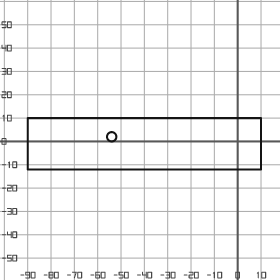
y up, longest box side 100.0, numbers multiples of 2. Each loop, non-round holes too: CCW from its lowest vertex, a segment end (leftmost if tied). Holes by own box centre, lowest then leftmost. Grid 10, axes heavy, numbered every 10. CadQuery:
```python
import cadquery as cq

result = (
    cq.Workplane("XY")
    .moveTo(-90.0, -12.0)
    .lineTo(10.0, -12.0)
    .lineTo(10.0, 10.0)
    .lineTo(-90.0, 10.0)
    .close()
    .moveTo(-54.0, 2.0)
    .circle(2.0)
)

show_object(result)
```